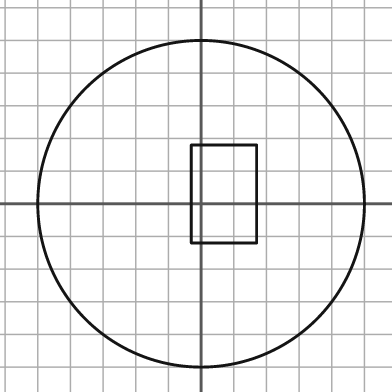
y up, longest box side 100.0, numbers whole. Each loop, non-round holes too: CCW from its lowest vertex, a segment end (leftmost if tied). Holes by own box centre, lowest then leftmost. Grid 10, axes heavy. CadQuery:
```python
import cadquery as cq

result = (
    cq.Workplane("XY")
    .moveTo(0.0, 0.0)
    .circle(50.0)
    .moveTo(-3.0, -12.0)
    .lineTo(17.0, -12.0)
    .lineTo(17.0, 18.0)
    .lineTo(-3.0, 18.0)
    .close()
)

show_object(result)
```